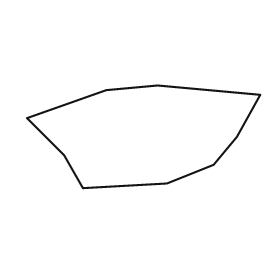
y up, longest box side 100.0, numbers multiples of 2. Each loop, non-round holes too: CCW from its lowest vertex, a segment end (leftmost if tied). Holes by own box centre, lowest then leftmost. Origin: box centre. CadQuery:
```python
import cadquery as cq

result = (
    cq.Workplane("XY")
    .moveTo(-26.0, -22.0)
    .lineTo(10.0, -20.0)
    .lineTo(30.0, -12.0)
    .lineTo(40.0, 0.0)
    .lineTo(50.0, 18.0)
    .lineTo(6.0, 22.0)
    .lineTo(-16.0, 20.0)
    .lineTo(-50.0, 8.0)
    .lineTo(-34.0, -8.0)
    .close()
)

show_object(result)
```